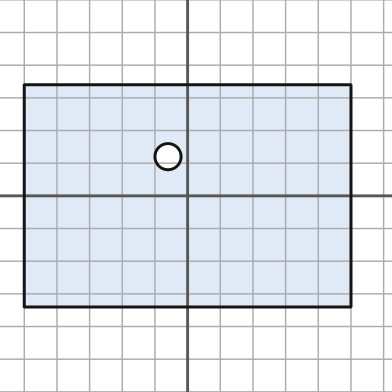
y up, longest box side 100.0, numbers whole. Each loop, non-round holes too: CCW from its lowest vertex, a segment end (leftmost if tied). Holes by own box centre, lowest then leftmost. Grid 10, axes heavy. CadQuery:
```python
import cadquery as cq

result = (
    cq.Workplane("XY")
    .moveTo(-50.0, -34.0)
    .lineTo(50.0, -34.0)
    .lineTo(50.0, 34.0)
    .lineTo(-50.0, 34.0)
    .close()
    .moveTo(-6.0, 12.0)
    .circle(4.0)
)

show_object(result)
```